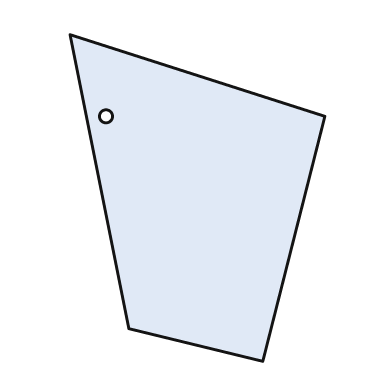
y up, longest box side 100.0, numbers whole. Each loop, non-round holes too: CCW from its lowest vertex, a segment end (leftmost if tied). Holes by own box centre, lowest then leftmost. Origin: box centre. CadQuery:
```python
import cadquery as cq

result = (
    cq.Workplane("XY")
    .moveTo(20.0, -50.0)
    .lineTo(39.0, 25.0)
    .lineTo(-39.0, 50.0)
    .lineTo(-21.0, -40.0)
    .close()
    .moveTo(-28.0, 25.0)
    .circle(2.0)
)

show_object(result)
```